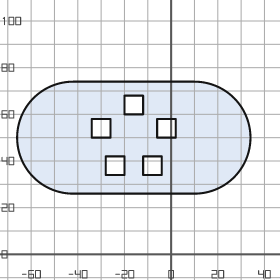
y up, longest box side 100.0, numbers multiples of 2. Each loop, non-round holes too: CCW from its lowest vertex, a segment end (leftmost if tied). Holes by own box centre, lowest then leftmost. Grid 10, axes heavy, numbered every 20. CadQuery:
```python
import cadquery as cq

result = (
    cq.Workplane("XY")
    .moveTo(-42.0, 26.0)
    .lineTo(10.0, 26.0)
    .threePointArc((34.0, 50.0), (10.0, 74.0))
    .lineTo(-42.0, 74.0)
    .threePointArc((-66.0, 50.0), (-42.0, 26.0))
    .close()
    .moveTo(-28.0, 34.0)
    .lineTo(-20.0, 34.0)
    .lineTo(-20.0, 42.0)
    .lineTo(-28.0, 42.0)
    .close()
    .moveTo(-12.0, 34.0)
    .lineTo(-4.0, 34.0)
    .lineTo(-4.0, 42.0)
    .lineTo(-12.0, 42.0)
    .close()
    .moveTo(-34.0, 50.0)
    .lineTo(-26.0, 50.0)
    .lineTo(-26.0, 58.0)
    .lineTo(-34.0, 58.0)
    .close()
    .moveTo(-6.0, 50.0)
    .lineTo(2.0, 50.0)
    .lineTo(2.0, 58.0)
    .lineTo(-6.0, 58.0)
    .close()
    .moveTo(-20.0, 60.0)
    .lineTo(-12.0, 60.0)
    .lineTo(-12.0, 68.0)
    .lineTo(-20.0, 68.0)
    .close()
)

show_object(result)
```